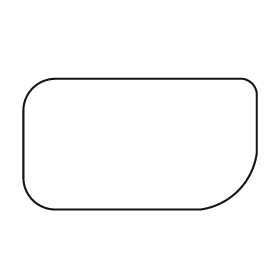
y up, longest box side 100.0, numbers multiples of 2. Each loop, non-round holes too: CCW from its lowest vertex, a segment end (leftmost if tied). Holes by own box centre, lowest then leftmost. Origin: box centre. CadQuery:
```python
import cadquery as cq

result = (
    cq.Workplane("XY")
    .moveTo(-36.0, -28.0)
    .lineTo(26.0, -28.0)
    .threePointArc((42.0, -20.0), (50.0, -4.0))
    .lineTo(50.0, 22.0)
    .threePointArc((48.0, 26.0), (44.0, 28.0))
    .lineTo(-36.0, 28.0)
    .threePointArc((-46.0, 24.0), (-50.0, 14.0))
    .lineTo(-50.0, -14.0)
    .threePointArc((-46.0, -24.0), (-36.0, -28.0))
    .close()
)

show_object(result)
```